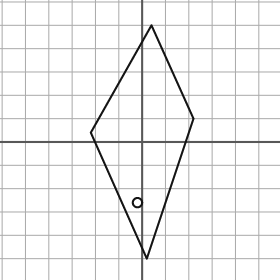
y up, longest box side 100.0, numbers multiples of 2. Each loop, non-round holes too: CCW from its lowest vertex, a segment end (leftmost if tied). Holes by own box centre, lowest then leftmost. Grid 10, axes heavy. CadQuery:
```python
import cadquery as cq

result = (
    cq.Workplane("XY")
    .moveTo(2.0, -50.0)
    .lineTo(22.0, 10.0)
    .lineTo(4.0, 50.0)
    .lineTo(-22.0, 4.0)
    .close()
    .moveTo(-2.0, -26.0)
    .circle(2.0)
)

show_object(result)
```